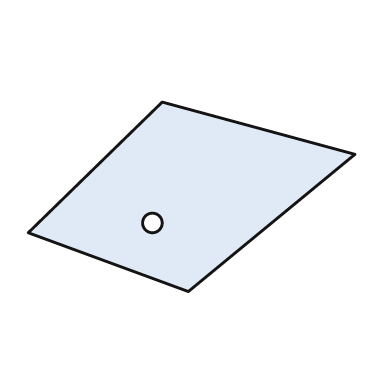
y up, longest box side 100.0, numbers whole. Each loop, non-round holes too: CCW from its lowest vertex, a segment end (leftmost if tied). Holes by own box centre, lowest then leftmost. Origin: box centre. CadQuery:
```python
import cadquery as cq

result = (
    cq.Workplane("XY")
    .moveTo(-1.0, -29.0)
    .lineTo(50.0, 13.0)
    .lineTo(-9.0, 29.0)
    .lineTo(-50.0, -11.0)
    .close()
    .moveTo(-12.0, -8.0)
    .circle(3.0)
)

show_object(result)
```